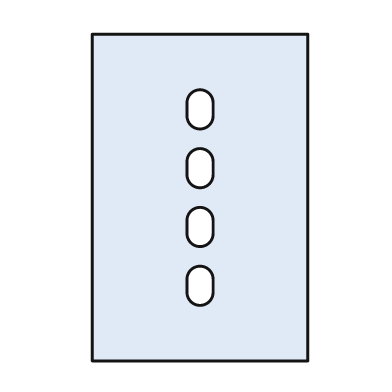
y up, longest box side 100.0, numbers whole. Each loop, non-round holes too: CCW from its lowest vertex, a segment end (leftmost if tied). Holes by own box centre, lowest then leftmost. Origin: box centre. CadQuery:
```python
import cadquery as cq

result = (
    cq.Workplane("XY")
    .moveTo(-33.0, -50.0)
    .lineTo(33.0, -50.0)
    .lineTo(33.0, 50.0)
    .lineTo(-33.0, 50.0)
    .close()
    .moveTo(-4.0, -29.0)
    .threePointArc((0.0, -33.0), (4.0, -29.0))
    .lineTo(4.0, -25.0)
    .threePointArc((0.0, -21.0), (-4.0, -25.0))
    .close()
    .moveTo(-4.0, -11.0)
    .threePointArc((0.0, -15.0), (4.0, -11.0))
    .lineTo(4.0, -7.0)
    .threePointArc((0.0, -3.0), (-4.0, -7.0))
    .close()
    .moveTo(-4.0, 7.0)
    .threePointArc((0.0, 3.0), (4.0, 7.0))
    .lineTo(4.0, 11.0)
    .threePointArc((0.0, 15.0), (-4.0, 11.0))
    .close()
    .moveTo(-4.0, 25.0)
    .threePointArc((0.0, 21.0), (4.0, 25.0))
    .lineTo(4.0, 29.0)
    .threePointArc((0.0, 33.0), (-4.0, 29.0))
    .close()
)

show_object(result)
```